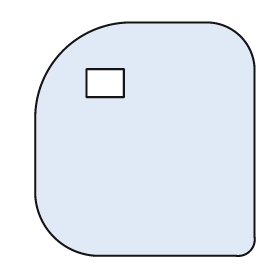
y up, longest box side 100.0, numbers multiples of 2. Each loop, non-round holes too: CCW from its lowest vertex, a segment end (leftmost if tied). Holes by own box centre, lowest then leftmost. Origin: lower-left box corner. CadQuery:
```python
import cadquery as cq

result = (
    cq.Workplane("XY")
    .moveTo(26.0, 0.0)
    .lineTo(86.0, 0.0)
    .threePointArc((92.0, 2.0), (94.0, 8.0))
    .lineTo(94.0, 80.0)
    .threePointArc((88.0, 94.0), (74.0, 100.0))
    .lineTo(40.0, 100.0)
    .threePointArc((12.0, 88.0), (0.0, 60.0))
    .lineTo(0.0, 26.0)
    .threePointArc((8.0, 8.0), (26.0, 0.0))
    .close()
    .moveTo(22.0, 68.0)
    .lineTo(38.0, 68.0)
    .lineTo(38.0, 80.0)
    .lineTo(22.0, 80.0)
    .close()
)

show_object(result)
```